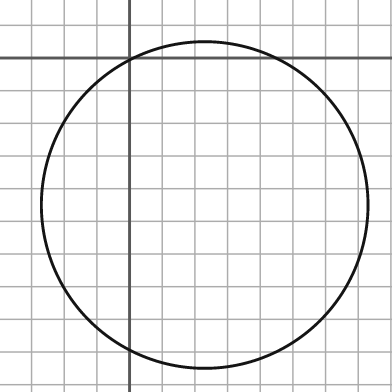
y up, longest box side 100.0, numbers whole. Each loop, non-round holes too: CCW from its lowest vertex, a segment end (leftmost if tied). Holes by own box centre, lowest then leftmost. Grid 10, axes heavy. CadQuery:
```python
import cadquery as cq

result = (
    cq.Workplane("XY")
    .moveTo(23.0, -45.0)
    .circle(50.0)
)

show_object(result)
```